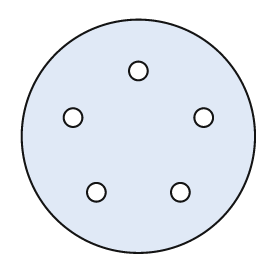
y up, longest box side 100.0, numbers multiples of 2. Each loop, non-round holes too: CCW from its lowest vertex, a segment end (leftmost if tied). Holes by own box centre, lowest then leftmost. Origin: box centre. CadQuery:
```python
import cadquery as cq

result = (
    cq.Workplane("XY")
    .moveTo(0.0, 0.0)
    .circle(50.0)
    .moveTo(-18.0, -24.0)
    .circle(4.0)
    .moveTo(18.0, -24.0)
    .circle(4.0)
    .moveTo(-28.0, 8.0)
    .circle(4.0)
    .moveTo(28.0, 8.0)
    .circle(4.0)
    .moveTo(0.0, 28.0)
    .circle(4.0)
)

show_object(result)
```